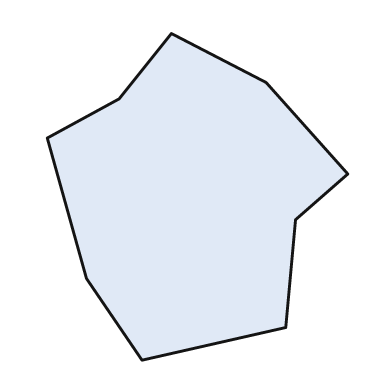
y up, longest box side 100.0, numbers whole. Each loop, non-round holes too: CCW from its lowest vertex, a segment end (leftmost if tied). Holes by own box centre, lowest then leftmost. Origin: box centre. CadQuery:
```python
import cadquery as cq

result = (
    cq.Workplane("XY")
    .moveTo(-17.0, -50.0)
    .lineTo(27.0, -40.0)
    .lineTo(30.0, -7.0)
    .lineTo(46.0, 7.0)
    .lineTo(21.0, 35.0)
    .lineTo(-8.0, 50.0)
    .lineTo(-24.0, 30.0)
    .lineTo(-46.0, 18.0)
    .lineTo(-34.0, -25.0)
    .close()
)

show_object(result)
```